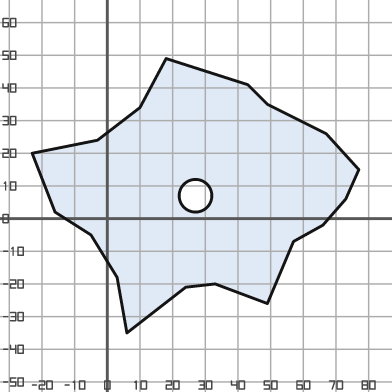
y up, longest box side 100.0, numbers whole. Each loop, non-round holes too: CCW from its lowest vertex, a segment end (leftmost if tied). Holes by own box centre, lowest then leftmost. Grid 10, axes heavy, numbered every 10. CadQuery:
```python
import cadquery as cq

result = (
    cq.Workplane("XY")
    .moveTo(6.0, -35.0)
    .lineTo(24.0, -21.0)
    .lineTo(33.0, -20.0)
    .lineTo(49.0, -26.0)
    .lineTo(57.0, -7.0)
    .lineTo(66.0, -2.0)
    .lineTo(73.0, 6.0)
    .lineTo(77.0, 15.0)
    .lineTo(67.0, 26.0)
    .lineTo(49.0, 35.0)
    .lineTo(43.0, 41.0)
    .lineTo(18.0, 49.0)
    .lineTo(10.0, 34.0)
    .lineTo(-3.0, 24.0)
    .lineTo(-23.0, 20.0)
    .lineTo(-16.0, 2.0)
    .lineTo(-5.0, -5.0)
    .lineTo(3.0, -18.0)
    .close()
    .moveTo(27.0, 7.0)
    .circle(5.0)
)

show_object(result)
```